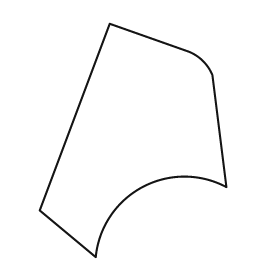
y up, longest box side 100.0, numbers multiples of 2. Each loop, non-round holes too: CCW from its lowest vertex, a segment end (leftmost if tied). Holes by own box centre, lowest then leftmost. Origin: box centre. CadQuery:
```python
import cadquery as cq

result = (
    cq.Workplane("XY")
    .moveTo(-16.0, -50.0)
    .threePointArc((4.0, -20.0), (40.0, -20.0))
    .lineTo(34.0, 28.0)
    .threePointArc((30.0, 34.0), (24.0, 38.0))
    .lineTo(-10.0, 50.0)
    .lineTo(-40.0, -30.0)
    .close()
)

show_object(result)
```